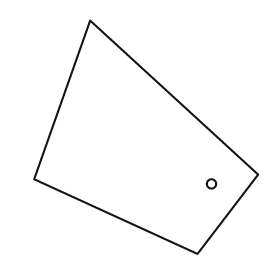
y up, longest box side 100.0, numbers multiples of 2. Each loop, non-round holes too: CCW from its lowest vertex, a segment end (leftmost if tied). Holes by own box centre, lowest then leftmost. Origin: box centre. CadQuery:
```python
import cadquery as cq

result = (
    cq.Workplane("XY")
    .moveTo(22.0, -50.0)
    .lineTo(48.0, -16.0)
    .lineTo(-24.0, 50.0)
    .lineTo(-48.0, -18.0)
    .close()
    .moveTo(28.0, -20.0)
    .circle(2.0)
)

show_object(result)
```